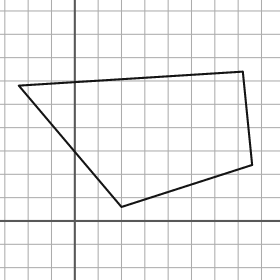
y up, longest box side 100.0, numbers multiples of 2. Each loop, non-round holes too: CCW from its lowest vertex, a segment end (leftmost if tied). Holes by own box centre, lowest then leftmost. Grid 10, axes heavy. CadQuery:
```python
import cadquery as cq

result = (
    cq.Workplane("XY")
    .moveTo(20.0, 6.0)
    .lineTo(76.0, 24.0)
    .lineTo(72.0, 64.0)
    .lineTo(-24.0, 58.0)
    .close()
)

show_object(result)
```